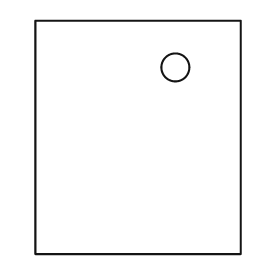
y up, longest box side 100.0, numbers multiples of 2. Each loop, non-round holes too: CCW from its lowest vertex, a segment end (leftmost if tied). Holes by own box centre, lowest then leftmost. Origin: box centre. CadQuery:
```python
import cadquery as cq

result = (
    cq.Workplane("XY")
    .moveTo(-44.0, -50.0)
    .lineTo(44.0, -50.0)
    .lineTo(44.0, 50.0)
    .lineTo(-44.0, 50.0)
    .close()
    .moveTo(16.0, 30.0)
    .circle(6.0)
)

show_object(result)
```